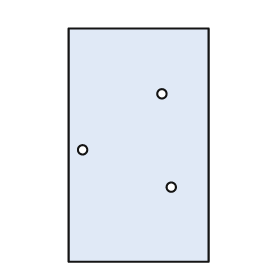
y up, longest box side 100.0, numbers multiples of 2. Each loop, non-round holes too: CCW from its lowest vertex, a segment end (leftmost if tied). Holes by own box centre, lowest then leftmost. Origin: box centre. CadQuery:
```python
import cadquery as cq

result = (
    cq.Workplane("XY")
    .moveTo(-30.0, -50.0)
    .lineTo(30.0, -50.0)
    .lineTo(30.0, 50.0)
    .lineTo(-30.0, 50.0)
    .close()
    .moveTo(14.0, -18.0)
    .circle(2.0)
    .moveTo(-24.0, -2.0)
    .circle(2.0)
    .moveTo(10.0, 22.0)
    .circle(2.0)
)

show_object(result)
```